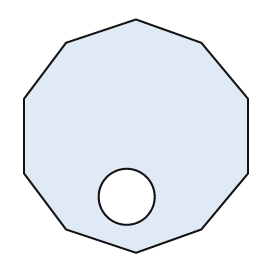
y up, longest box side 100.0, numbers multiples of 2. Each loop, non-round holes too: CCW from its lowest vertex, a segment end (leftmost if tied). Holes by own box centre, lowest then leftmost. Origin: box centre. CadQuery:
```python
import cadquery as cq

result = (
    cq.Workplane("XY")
    .moveTo(0.0, -50.0)
    .lineTo(28.0, -40.0)
    .lineTo(48.0, -16.0)
    .lineTo(48.0, 16.0)
    .lineTo(28.0, 40.0)
    .lineTo(0.0, 50.0)
    .lineTo(-30.0, 40.0)
    .lineTo(-48.0, 16.0)
    .lineTo(-48.0, -16.0)
    .lineTo(-30.0, -40.0)
    .close()
    .moveTo(-4.0, -26.0)
    .circle(12.0)
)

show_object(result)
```